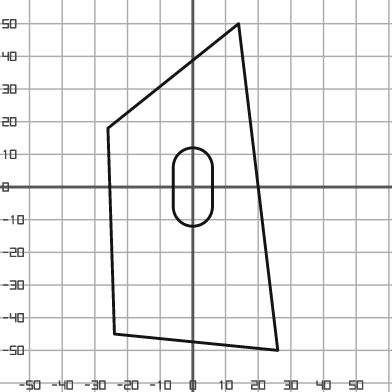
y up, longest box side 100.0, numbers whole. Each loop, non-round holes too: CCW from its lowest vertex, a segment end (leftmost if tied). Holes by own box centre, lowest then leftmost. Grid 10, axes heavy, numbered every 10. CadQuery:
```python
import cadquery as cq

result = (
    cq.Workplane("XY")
    .moveTo(26.0, -50.0)
    .lineTo(14.0, 50.0)
    .lineTo(-26.0, 18.0)
    .lineTo(-24.0, -45.0)
    .close()
    .moveTo(-6.0, -6.0)
    .threePointArc((0.0, -12.0), (6.0, -6.0))
    .lineTo(6.0, 6.0)
    .threePointArc((0.0, 12.0), (-6.0, 6.0))
    .close()
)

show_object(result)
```